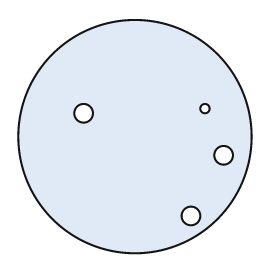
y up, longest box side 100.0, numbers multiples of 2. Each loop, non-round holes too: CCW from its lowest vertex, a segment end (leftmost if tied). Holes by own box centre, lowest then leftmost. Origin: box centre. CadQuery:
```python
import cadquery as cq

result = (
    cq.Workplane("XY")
    .moveTo(0.0, 0.0)
    .circle(50.0)
    .moveTo(24.0, -34.0)
    .circle(4.0)
    .moveTo(38.0, -8.0)
    .circle(4.0)
    .moveTo(-22.0, 10.0)
    .circle(4.0)
    .moveTo(30.0, 12.0)
    .circle(2.0)
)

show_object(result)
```